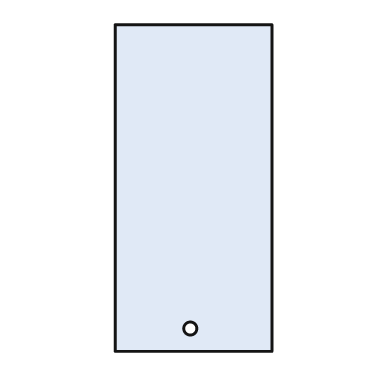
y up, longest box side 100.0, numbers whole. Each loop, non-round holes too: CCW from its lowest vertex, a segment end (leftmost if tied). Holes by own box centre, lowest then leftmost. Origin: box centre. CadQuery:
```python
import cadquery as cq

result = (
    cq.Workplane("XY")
    .moveTo(-24.0, -50.0)
    .lineTo(24.0, -50.0)
    .lineTo(24.0, 50.0)
    .lineTo(-24.0, 50.0)
    .close()
    .moveTo(-1.0, -43.0)
    .circle(2.0)
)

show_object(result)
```